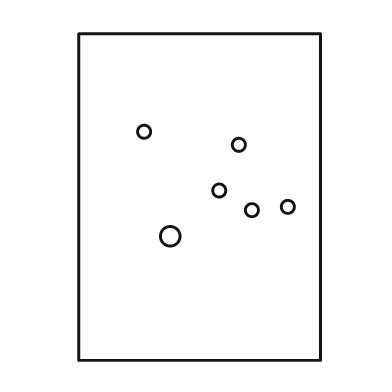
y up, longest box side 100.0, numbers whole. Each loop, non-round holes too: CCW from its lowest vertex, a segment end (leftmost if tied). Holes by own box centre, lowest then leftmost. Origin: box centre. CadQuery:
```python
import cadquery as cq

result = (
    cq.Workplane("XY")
    .moveTo(-37.0, -50.0)
    .lineTo(37.0, -50.0)
    .lineTo(37.0, 50.0)
    .lineTo(-37.0, 50.0)
    .close()
    .moveTo(-9.0, -12.0)
    .circle(3.0)
    .moveTo(16.0, -4.0)
    .circle(2.0)
    .moveTo(27.0, -3.0)
    .circle(2.0)
    .moveTo(6.0, 2.0)
    .circle(2.0)
    .moveTo(12.0, 16.0)
    .circle(2.0)
    .moveTo(-17.0, 20.0)
    .circle(2.0)
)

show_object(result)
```